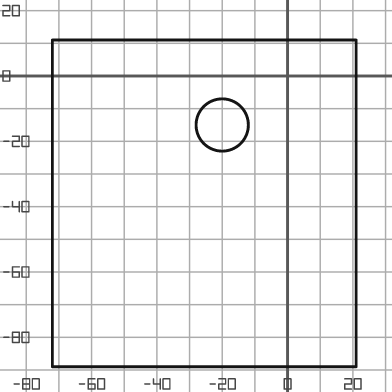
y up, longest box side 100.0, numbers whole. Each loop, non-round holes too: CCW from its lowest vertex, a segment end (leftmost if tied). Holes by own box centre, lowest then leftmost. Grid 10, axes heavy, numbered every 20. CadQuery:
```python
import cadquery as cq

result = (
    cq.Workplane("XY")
    .moveTo(-72.0, -89.0)
    .lineTo(21.0, -89.0)
    .lineTo(21.0, 11.0)
    .lineTo(-72.0, 11.0)
    .close()
    .moveTo(-20.0, -15.0)
    .circle(8.0)
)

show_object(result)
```